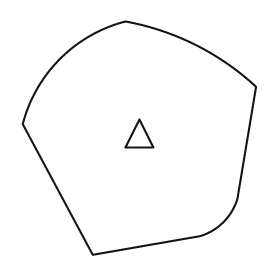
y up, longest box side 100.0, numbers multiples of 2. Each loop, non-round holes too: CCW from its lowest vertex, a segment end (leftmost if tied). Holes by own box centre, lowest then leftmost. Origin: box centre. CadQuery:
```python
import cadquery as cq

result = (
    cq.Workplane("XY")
    .moveTo(-20.0, -50.0)
    .lineTo(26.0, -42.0)
    .threePointArc((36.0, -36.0), (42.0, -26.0))
    .lineTo(50.0, 22.0)
    .threePointArc((24.0, 40.0), (-6.0, 50.0))
    .threePointArc((-34.0, 34.0), (-50.0, 6.0))
    .close()
    .moveTo(-6.0, -4.0)
    .lineTo(6.0, -4.0)
    .lineTo(0.0, 8.0)
    .close()
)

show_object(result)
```